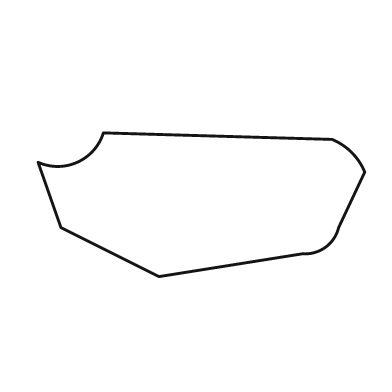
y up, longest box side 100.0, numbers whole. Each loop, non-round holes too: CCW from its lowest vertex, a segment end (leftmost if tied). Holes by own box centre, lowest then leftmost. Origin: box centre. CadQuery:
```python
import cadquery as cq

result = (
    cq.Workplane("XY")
    .moveTo(-13.0, -22.0)
    .lineTo(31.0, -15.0)
    .threePointArc((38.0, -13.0), (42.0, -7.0))
    .lineTo(50.0, 10.0)
    .threePointArc((46.0, 16.0), (40.0, 20.0))
    .lineTo(-30.0, 22.0)
    .threePointArc((-38.0, 13.0), (-50.0, 13.0))
    .lineTo(-43.0, -7.0)
    .close()
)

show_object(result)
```